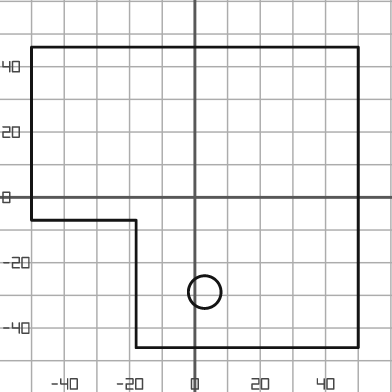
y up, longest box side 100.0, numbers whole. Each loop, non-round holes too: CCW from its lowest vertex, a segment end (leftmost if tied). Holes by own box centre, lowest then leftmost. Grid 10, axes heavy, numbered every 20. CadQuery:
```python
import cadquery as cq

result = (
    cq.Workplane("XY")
    .moveTo(-18.0, -46.0)
    .lineTo(50.0, -46.0)
    .lineTo(50.0, 46.0)
    .lineTo(-50.0, 46.0)
    .lineTo(-50.0, -7.0)
    .lineTo(-18.0, -7.0)
    .close()
    .moveTo(3.0, -29.0)
    .circle(5.0)
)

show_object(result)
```